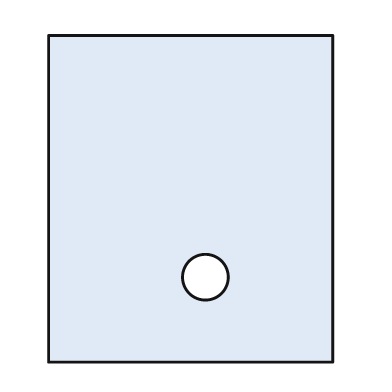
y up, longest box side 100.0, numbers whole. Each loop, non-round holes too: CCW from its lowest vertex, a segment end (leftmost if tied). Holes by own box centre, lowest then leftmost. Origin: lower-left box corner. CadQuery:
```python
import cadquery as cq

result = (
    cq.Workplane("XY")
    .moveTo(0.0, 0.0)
    .lineTo(87.0, 0.0)
    .lineTo(87.0, 100.0)
    .lineTo(0.0, 100.0)
    .close()
    .moveTo(48.0, 26.0)
    .circle(7.0)
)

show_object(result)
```